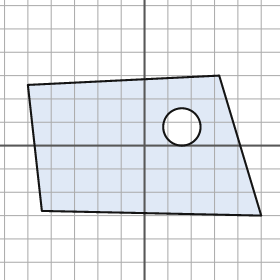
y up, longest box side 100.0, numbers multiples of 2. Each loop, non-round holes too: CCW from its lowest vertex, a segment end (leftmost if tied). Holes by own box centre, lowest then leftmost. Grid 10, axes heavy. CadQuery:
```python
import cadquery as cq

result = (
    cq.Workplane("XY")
    .moveTo(50.0, -30.0)
    .lineTo(32.0, 30.0)
    .lineTo(-50.0, 26.0)
    .lineTo(-44.0, -28.0)
    .close()
    .moveTo(16.0, 8.0)
    .circle(8.0)
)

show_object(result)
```